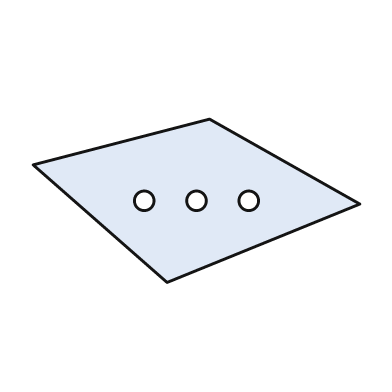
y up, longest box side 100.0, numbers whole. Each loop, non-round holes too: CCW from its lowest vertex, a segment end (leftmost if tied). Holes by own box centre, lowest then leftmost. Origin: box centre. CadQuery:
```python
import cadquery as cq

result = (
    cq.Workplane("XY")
    .moveTo(-9.0, -25.0)
    .lineTo(50.0, -1.0)
    .lineTo(4.0, 25.0)
    .lineTo(-50.0, 11.0)
    .close()
    .moveTo(-16.0, 0.0)
    .circle(3.0)
    .moveTo(0.0, 0.0)
    .circle(3.0)
    .moveTo(16.0, 0.0)
    .circle(3.0)
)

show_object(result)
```